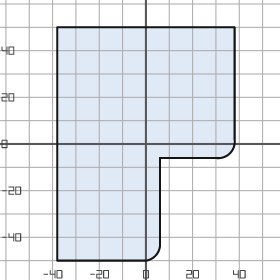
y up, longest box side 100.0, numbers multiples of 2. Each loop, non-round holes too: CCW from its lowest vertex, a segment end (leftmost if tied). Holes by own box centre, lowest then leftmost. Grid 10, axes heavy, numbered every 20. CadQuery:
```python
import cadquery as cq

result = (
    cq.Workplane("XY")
    .moveTo(-38.0, -50.0)
    .lineTo(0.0, -50.0)
    .threePointArc((4.0, -48.0), (6.0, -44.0))
    .lineTo(6.0, -6.0)
    .lineTo(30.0, -6.0)
    .threePointArc((36.0, -4.0), (38.0, 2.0))
    .lineTo(38.0, 50.0)
    .lineTo(-38.0, 50.0)
    .close()
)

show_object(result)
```